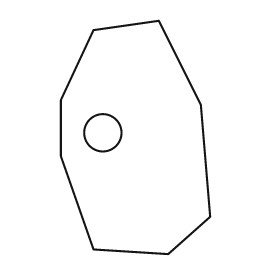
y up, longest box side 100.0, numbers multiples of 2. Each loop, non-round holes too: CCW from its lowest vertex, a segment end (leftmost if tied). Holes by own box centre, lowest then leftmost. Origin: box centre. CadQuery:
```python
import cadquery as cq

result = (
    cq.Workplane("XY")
    .moveTo(14.0, -50.0)
    .lineTo(32.0, -34.0)
    .lineTo(28.0, 14.0)
    .lineTo(10.0, 50.0)
    .lineTo(-18.0, 46.0)
    .lineTo(-32.0, 16.0)
    .lineTo(-32.0, -8.0)
    .lineTo(-18.0, -48.0)
    .close()
    .moveTo(-14.0, 2.0)
    .circle(8.0)
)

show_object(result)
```